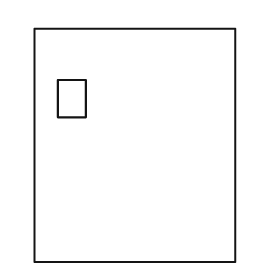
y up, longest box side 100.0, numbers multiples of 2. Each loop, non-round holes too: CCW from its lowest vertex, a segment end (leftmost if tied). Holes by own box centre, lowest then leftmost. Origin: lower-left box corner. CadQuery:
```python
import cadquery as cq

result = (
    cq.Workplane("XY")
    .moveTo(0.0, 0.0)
    .lineTo(86.0, 0.0)
    .lineTo(86.0, 100.0)
    .lineTo(0.0, 100.0)
    .close()
    .moveTo(10.0, 62.0)
    .lineTo(22.0, 62.0)
    .lineTo(22.0, 78.0)
    .lineTo(10.0, 78.0)
    .close()
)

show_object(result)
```